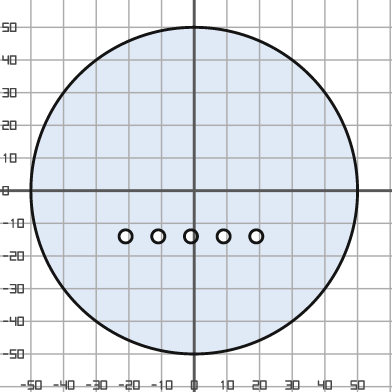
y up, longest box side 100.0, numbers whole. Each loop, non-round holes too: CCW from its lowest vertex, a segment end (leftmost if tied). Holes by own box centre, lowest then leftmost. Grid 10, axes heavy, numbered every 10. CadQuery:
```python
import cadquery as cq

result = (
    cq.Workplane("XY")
    .moveTo(0.0, 0.0)
    .circle(50.0)
    .moveTo(-21.0, -14.0)
    .circle(2.0)
    .moveTo(-11.0, -14.0)
    .circle(2.0)
    .moveTo(-1.0, -14.0)
    .circle(2.0)
    .moveTo(9.0, -14.0)
    .circle(2.0)
    .moveTo(19.0, -14.0)
    .circle(2.0)
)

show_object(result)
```